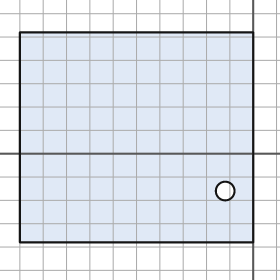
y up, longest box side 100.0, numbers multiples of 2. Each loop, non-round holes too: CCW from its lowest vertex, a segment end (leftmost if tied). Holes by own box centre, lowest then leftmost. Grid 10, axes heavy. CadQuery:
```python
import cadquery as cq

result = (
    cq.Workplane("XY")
    .moveTo(-100.0, -38.0)
    .lineTo(0.0, -38.0)
    .lineTo(0.0, 52.0)
    .lineTo(-100.0, 52.0)
    .close()
    .moveTo(-12.0, -16.0)
    .circle(4.0)
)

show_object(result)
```